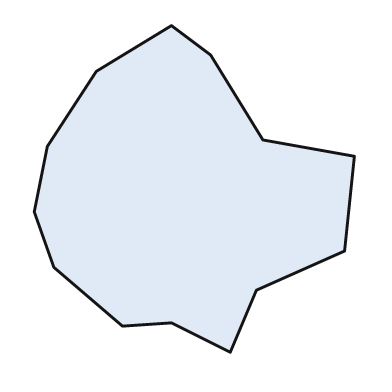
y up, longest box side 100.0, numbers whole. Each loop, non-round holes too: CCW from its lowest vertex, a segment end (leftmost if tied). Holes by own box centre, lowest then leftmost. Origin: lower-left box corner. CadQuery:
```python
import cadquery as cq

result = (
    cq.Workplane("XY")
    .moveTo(60.0, 0.0)
    .lineTo(68.0, 19.0)
    .lineTo(95.0, 31.0)
    .lineTo(98.0, 60.0)
    .lineTo(70.0, 65.0)
    .lineTo(54.0, 91.0)
    .lineTo(42.0, 100.0)
    .lineTo(19.0, 86.0)
    .lineTo(4.0, 63.0)
    .lineTo(0.0, 43.0)
    .lineTo(6.0, 26.0)
    .lineTo(27.0, 8.0)
    .lineTo(42.0, 9.0)
    .close()
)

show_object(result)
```